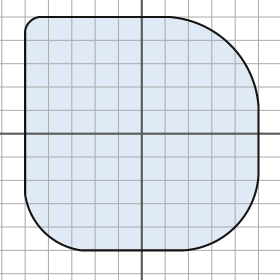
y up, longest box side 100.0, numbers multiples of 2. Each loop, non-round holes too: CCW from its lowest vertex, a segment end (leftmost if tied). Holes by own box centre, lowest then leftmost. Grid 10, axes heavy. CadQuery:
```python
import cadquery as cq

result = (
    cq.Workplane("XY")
    .moveTo(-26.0, -50.0)
    .lineTo(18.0, -50.0)
    .threePointArc((40.0, -40.0), (50.0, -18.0))
    .lineTo(50.0, 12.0)
    .threePointArc((38.0, 38.0), (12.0, 50.0))
    .lineTo(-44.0, 50.0)
    .threePointArc((-48.0, 48.0), (-50.0, 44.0))
    .lineTo(-50.0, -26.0)
    .threePointArc((-42.0, -42.0), (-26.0, -50.0))
    .close()
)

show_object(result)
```